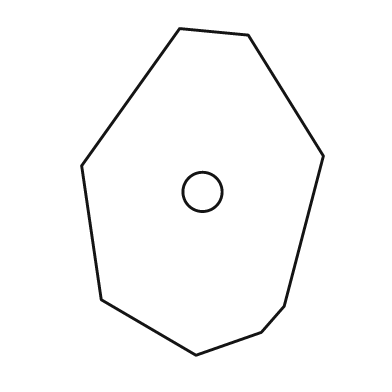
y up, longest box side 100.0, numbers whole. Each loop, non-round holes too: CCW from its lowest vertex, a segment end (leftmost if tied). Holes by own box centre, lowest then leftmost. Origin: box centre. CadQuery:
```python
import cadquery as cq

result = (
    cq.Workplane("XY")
    .moveTo(-2.0, -50.0)
    .lineTo(18.0, -43.0)
    .lineTo(25.0, -35.0)
    .lineTo(37.0, 11.0)
    .lineTo(14.0, 48.0)
    .lineTo(-7.0, 50.0)
    .lineTo(-37.0, 8.0)
    .lineTo(-31.0, -33.0)
    .close()
    .moveTo(0.0, 0.0)
    .circle(6.0)
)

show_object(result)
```